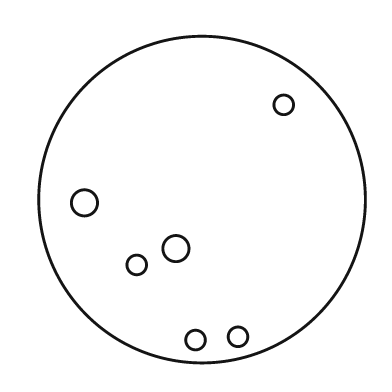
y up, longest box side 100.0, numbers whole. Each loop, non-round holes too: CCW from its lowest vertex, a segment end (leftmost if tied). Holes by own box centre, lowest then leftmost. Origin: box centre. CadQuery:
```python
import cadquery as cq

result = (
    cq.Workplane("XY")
    .moveTo(0.0, 0.0)
    .circle(50.0)
    .moveTo(-2.0, -43.0)
    .circle(3.0)
    .moveTo(11.0, -42.0)
    .circle(3.0)
    .moveTo(-20.0, -20.0)
    .circle(3.0)
    .moveTo(-8.0, -15.0)
    .circle(4.0)
    .moveTo(-36.0, -1.0)
    .circle(4.0)
    .moveTo(25.0, 29.0)
    .circle(3.0)
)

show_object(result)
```